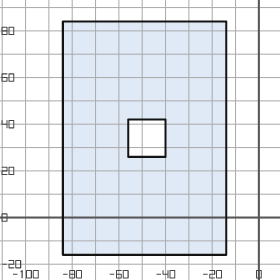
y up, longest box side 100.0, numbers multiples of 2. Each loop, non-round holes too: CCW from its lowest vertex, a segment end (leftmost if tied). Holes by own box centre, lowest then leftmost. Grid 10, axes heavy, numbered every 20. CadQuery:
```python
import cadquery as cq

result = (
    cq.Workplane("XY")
    .moveTo(-84.0, -16.0)
    .lineTo(-14.0, -16.0)
    .lineTo(-14.0, 84.0)
    .lineTo(-84.0, 84.0)
    .close()
    .moveTo(-56.0, 26.0)
    .lineTo(-40.0, 26.0)
    .lineTo(-40.0, 42.0)
    .lineTo(-56.0, 42.0)
    .close()
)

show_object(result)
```